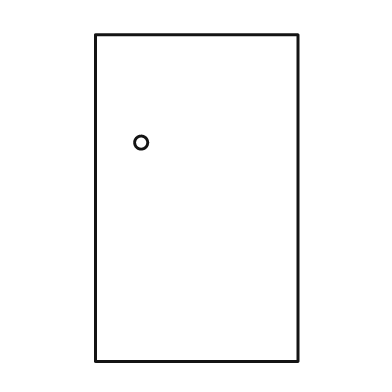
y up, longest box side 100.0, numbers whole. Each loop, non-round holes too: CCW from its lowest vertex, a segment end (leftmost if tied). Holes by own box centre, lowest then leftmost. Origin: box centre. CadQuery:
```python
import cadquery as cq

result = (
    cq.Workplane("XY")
    .moveTo(-31.0, -50.0)
    .lineTo(31.0, -50.0)
    .lineTo(31.0, 50.0)
    .lineTo(-31.0, 50.0)
    .close()
    .moveTo(-17.0, 17.0)
    .circle(2.0)
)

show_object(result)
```